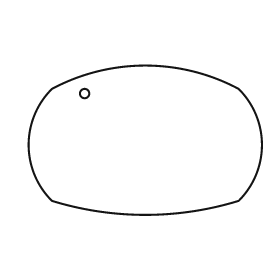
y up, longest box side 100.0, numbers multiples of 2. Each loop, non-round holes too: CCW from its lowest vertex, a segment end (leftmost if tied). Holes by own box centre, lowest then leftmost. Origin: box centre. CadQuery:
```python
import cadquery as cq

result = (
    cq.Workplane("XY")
    .moveTo(-40.0, -26.0)
    .threePointArc((0.0, -32.0), (40.0, -26.0))
    .threePointArc((50.0, -2.0), (40.0, 22.0))
    .threePointArc((0.0, 32.0), (-40.0, 22.0))
    .threePointArc((-50.0, -2.0), (-40.0, -26.0))
    .close()
    .moveTo(-26.0, 20.0)
    .circle(2.0)
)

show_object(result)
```